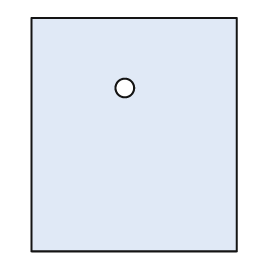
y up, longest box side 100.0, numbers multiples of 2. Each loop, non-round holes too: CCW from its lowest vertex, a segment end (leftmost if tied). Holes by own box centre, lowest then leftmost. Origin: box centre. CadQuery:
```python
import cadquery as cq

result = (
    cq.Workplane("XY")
    .moveTo(-44.0, -50.0)
    .lineTo(44.0, -50.0)
    .lineTo(44.0, 50.0)
    .lineTo(-44.0, 50.0)
    .close()
    .moveTo(-4.0, 20.0)
    .circle(4.0)
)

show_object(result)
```